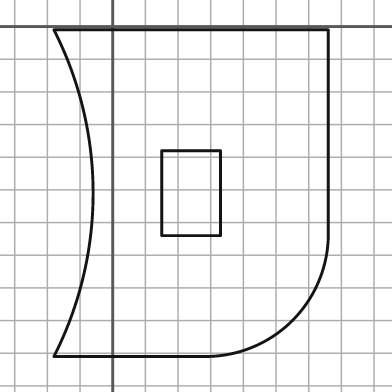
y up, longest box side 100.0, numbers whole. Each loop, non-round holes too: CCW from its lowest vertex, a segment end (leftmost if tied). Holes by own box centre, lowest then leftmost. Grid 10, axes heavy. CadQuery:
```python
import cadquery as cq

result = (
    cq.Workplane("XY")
    .moveTo(-18.0, -101.0)
    .lineTo(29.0, -101.0)
    .threePointArc((55.0, -90.0), (66.0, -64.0))
    .lineTo(66.0, -1.0)
    .lineTo(-18.0, -1.0)
    .threePointArc((-6.0, -51.0), (-18.0, -101.0))
    .close()
    .moveTo(15.0, -64.0)
    .lineTo(33.0, -64.0)
    .lineTo(33.0, -38.0)
    .lineTo(15.0, -38.0)
    .close()
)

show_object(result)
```